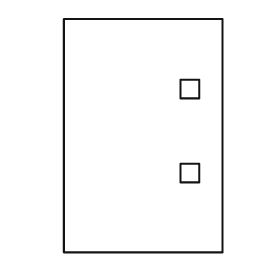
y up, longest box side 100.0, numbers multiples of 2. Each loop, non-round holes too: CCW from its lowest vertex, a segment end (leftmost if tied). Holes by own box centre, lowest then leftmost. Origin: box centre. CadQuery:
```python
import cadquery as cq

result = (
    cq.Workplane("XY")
    .moveTo(-34.0, -50.0)
    .lineTo(34.0, -50.0)
    .lineTo(34.0, 50.0)
    .lineTo(-34.0, 50.0)
    .close()
    .moveTo(16.0, -20.0)
    .lineTo(24.0, -20.0)
    .lineTo(24.0, -12.0)
    .lineTo(16.0, -12.0)
    .close()
    .moveTo(16.0, 16.0)
    .lineTo(24.0, 16.0)
    .lineTo(24.0, 24.0)
    .lineTo(16.0, 24.0)
    .close()
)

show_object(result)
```